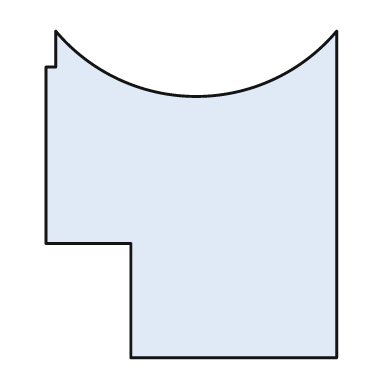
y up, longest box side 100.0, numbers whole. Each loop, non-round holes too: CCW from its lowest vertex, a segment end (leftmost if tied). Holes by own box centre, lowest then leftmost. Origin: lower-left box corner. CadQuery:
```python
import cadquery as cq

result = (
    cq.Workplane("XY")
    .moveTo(26.0, 0.0)
    .lineTo(89.0, 0.0)
    .lineTo(89.0, 100.0)
    .threePointArc((46.0, 80.0), (3.0, 100.0))
    .lineTo(3.0, 89.0)
    .lineTo(0.0, 89.0)
    .lineTo(0.0, 35.0)
    .lineTo(26.0, 35.0)
    .close()
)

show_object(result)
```